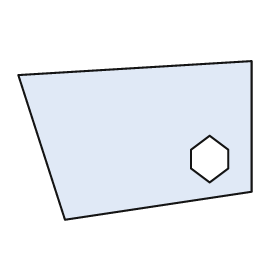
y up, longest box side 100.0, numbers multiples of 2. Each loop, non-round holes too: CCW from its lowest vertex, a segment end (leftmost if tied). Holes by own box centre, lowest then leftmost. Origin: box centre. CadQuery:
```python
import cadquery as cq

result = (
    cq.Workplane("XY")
    .moveTo(-30.0, -34.0)
    .lineTo(50.0, -22.0)
    .lineTo(50.0, 34.0)
    .lineTo(-50.0, 28.0)
    .close()
    .moveTo(32.0, -18.0)
    .lineTo(40.0, -12.0)
    .lineTo(40.0, -4.0)
    .lineTo(32.0, 2.0)
    .lineTo(24.0, -4.0)
    .lineTo(24.0, -12.0)
    .close()
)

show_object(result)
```